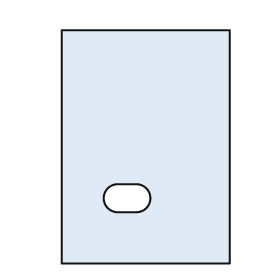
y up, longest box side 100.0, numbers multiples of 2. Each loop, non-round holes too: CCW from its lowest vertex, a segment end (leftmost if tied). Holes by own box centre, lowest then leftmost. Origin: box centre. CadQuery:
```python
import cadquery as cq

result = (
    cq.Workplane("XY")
    .moveTo(-36.0, -50.0)
    .lineTo(36.0, -50.0)
    .lineTo(36.0, 50.0)
    .lineTo(-36.0, 50.0)
    .close()
    .moveTo(-12.0, -28.0)
    .lineTo(-4.0, -28.0)
    .threePointArc((2.0, -22.0), (-4.0, -16.0))
    .lineTo(-12.0, -16.0)
    .threePointArc((-18.0, -22.0), (-12.0, -28.0))
    .close()
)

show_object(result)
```